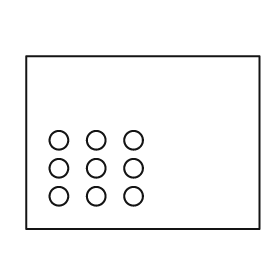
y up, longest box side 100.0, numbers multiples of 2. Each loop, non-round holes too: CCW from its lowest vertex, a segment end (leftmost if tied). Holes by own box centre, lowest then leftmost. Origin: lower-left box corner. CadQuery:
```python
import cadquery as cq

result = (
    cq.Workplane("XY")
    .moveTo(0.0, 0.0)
    .lineTo(100.0, 0.0)
    .lineTo(100.0, 74.0)
    .lineTo(0.0, 74.0)
    .close()
    .moveTo(14.0, 14.0)
    .circle(4.0)
    .moveTo(30.0, 14.0)
    .circle(4.0)
    .moveTo(46.0, 14.0)
    .circle(4.0)
    .moveTo(14.0, 26.0)
    .circle(4.0)
    .moveTo(30.0, 26.0)
    .circle(4.0)
    .moveTo(46.0, 26.0)
    .circle(4.0)
    .moveTo(14.0, 38.0)
    .circle(4.0)
    .moveTo(30.0, 38.0)
    .circle(4.0)
    .moveTo(46.0, 38.0)
    .circle(4.0)
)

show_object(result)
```